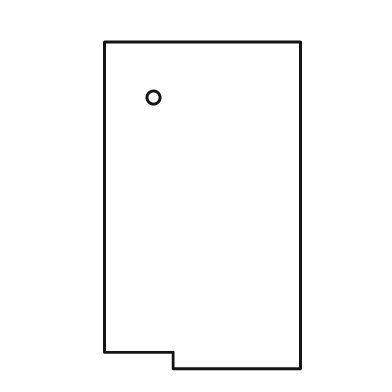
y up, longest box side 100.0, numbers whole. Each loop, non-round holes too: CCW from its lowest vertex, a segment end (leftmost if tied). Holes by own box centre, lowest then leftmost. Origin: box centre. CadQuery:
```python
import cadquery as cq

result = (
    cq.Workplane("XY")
    .moveTo(-9.0, -50.0)
    .lineTo(30.0, -50.0)
    .lineTo(30.0, 50.0)
    .lineTo(-30.0, 50.0)
    .lineTo(-30.0, -45.0)
    .lineTo(-9.0, -45.0)
    .close()
    .moveTo(-15.0, 33.0)
    .circle(2.0)
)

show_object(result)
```